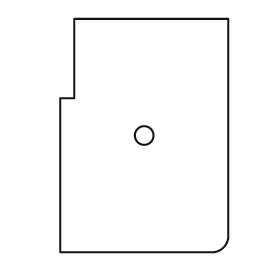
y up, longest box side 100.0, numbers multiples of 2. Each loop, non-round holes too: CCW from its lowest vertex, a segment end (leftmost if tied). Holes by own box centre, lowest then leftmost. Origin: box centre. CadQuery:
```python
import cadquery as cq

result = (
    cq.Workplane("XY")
    .moveTo(-36.0, -50.0)
    .lineTo(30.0, -50.0)
    .threePointArc((34.0, -48.0), (36.0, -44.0))
    .lineTo(36.0, 50.0)
    .lineTo(-30.0, 50.0)
    .lineTo(-30.0, 16.0)
    .lineTo(-36.0, 16.0)
    .close()
    .moveTo(0.0, 0.0)
    .circle(4.0)
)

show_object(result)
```